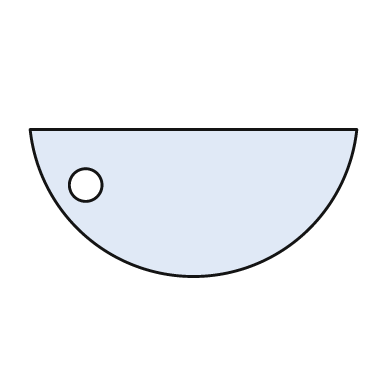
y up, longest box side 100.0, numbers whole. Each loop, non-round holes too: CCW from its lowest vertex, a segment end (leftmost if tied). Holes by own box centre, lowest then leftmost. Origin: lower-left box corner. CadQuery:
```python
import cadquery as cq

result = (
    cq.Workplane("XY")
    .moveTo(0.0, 45.0)
    .threePointArc((50.0, 0.0), (100.0, 45.0))
    .close()
    .moveTo(17.0, 28.0)
    .circle(5.0)
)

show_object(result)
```